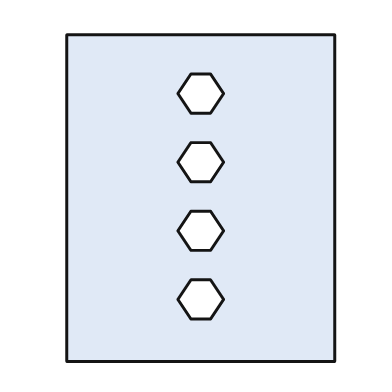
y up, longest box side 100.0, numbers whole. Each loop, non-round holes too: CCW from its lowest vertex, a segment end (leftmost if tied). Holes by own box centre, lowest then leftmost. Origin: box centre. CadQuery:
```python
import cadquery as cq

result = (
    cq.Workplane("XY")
    .moveTo(-41.0, -50.0)
    .lineTo(41.0, -50.0)
    .lineTo(41.0, 50.0)
    .lineTo(-41.0, 50.0)
    .close()
    .moveTo(-3.0, -37.0)
    .lineTo(3.0, -37.0)
    .lineTo(7.0, -31.0)
    .lineTo(3.0, -25.0)
    .lineTo(-3.0, -25.0)
    .lineTo(-7.0, -31.0)
    .close()
    .moveTo(-3.0, -16.0)
    .lineTo(3.0, -16.0)
    .lineTo(7.0, -10.0)
    .lineTo(3.0, -4.0)
    .lineTo(-3.0, -4.0)
    .lineTo(-7.0, -10.0)
    .close()
    .moveTo(-3.0, 5.0)
    .lineTo(3.0, 5.0)
    .lineTo(7.0, 11.0)
    .lineTo(3.0, 17.0)
    .lineTo(-3.0, 17.0)
    .lineTo(-7.0, 11.0)
    .close()
    .moveTo(-3.0, 26.0)
    .lineTo(3.0, 26.0)
    .lineTo(7.0, 32.0)
    .lineTo(3.0, 38.0)
    .lineTo(-3.0, 38.0)
    .lineTo(-7.0, 32.0)
    .close()
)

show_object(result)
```